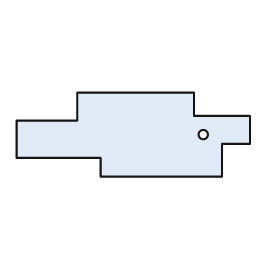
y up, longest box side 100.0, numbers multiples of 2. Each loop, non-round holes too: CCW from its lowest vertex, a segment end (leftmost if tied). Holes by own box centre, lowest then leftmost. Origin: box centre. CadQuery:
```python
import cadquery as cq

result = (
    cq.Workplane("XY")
    .moveTo(-14.0, -18.0)
    .lineTo(38.0, -18.0)
    .lineTo(38.0, -4.0)
    .lineTo(50.0, -4.0)
    .lineTo(50.0, 8.0)
    .lineTo(26.0, 8.0)
    .lineTo(26.0, 18.0)
    .lineTo(-24.0, 18.0)
    .lineTo(-24.0, 6.0)
    .lineTo(-50.0, 6.0)
    .lineTo(-50.0, -10.0)
    .lineTo(-14.0, -10.0)
    .close()
    .moveTo(30.0, 0.0)
    .circle(2.0)
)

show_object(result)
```